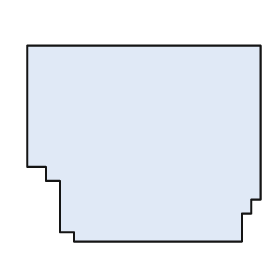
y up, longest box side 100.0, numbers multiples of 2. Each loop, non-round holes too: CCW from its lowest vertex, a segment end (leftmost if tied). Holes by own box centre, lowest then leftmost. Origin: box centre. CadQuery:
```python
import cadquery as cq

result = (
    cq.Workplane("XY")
    .moveTo(-30.0, -42.0)
    .lineTo(42.0, -42.0)
    .lineTo(42.0, -30.0)
    .lineTo(46.0, -30.0)
    .lineTo(46.0, -24.0)
    .lineTo(50.0, -24.0)
    .lineTo(50.0, 42.0)
    .lineTo(-50.0, 42.0)
    .lineTo(-50.0, -10.0)
    .lineTo(-42.0, -10.0)
    .lineTo(-42.0, -16.0)
    .lineTo(-36.0, -16.0)
    .lineTo(-36.0, -38.0)
    .lineTo(-30.0, -38.0)
    .close()
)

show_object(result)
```